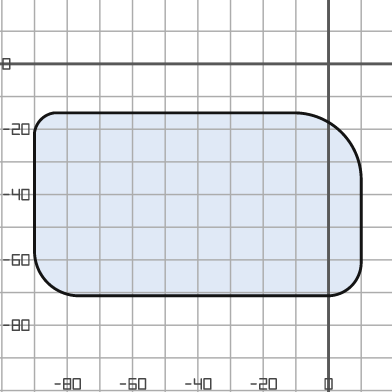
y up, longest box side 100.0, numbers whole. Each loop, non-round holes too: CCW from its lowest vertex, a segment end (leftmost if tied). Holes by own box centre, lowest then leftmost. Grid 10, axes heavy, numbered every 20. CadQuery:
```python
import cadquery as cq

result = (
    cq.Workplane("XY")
    .moveTo(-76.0, -71.0)
    .lineTo(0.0, -71.0)
    .threePointArc((7.0, -68.0), (10.0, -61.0))
    .lineTo(10.0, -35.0)
    .threePointArc((4.0, -21.0), (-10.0, -15.0))
    .lineTo(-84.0, -15.0)
    .threePointArc((-88.0, -17.0), (-90.0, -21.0))
    .lineTo(-90.0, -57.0)
    .threePointArc((-86.0, -67.0), (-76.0, -71.0))
    .close()
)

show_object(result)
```